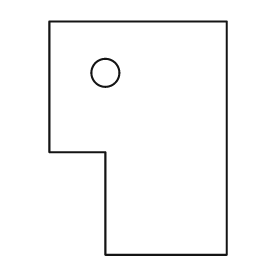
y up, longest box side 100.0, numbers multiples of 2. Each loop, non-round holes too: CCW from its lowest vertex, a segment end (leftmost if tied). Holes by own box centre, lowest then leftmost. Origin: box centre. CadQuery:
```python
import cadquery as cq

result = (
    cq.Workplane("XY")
    .moveTo(-14.0, -50.0)
    .lineTo(38.0, -50.0)
    .lineTo(38.0, 50.0)
    .lineTo(-38.0, 50.0)
    .lineTo(-38.0, -6.0)
    .lineTo(-14.0, -6.0)
    .close()
    .moveTo(-14.0, 28.0)
    .circle(6.0)
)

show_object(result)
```